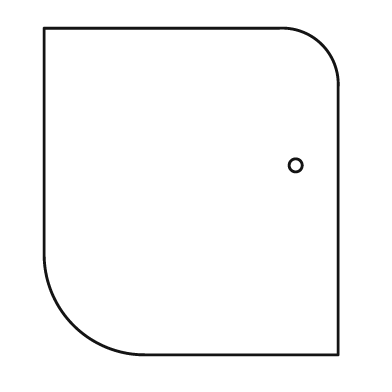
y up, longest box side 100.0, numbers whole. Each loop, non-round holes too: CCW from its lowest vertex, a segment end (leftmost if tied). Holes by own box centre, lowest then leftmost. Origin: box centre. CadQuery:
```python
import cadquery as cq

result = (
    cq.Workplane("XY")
    .moveTo(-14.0, -50.0)
    .lineTo(45.0, -50.0)
    .lineTo(45.0, 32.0)
    .threePointArc((40.0, 45.0), (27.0, 50.0))
    .lineTo(-45.0, 50.0)
    .lineTo(-45.0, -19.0)
    .threePointArc((-36.0, -41.0), (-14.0, -50.0))
    .close()
    .moveTo(32.0, 8.0)
    .circle(2.0)
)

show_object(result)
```